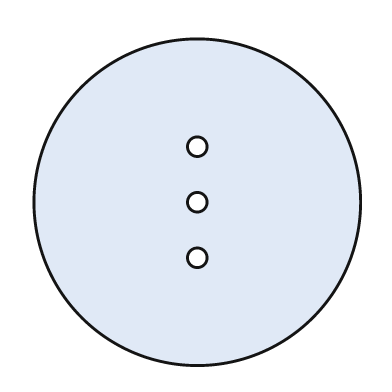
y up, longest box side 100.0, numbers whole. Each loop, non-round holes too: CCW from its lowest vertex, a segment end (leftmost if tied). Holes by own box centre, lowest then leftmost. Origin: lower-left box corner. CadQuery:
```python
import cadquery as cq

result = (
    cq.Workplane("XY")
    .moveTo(50.0, 50.0)
    .circle(50.0)
    .moveTo(50.0, 33.0)
    .circle(3.0)
    .moveTo(50.0, 50.0)
    .circle(3.0)
    .moveTo(50.0, 67.0)
    .circle(3.0)
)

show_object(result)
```